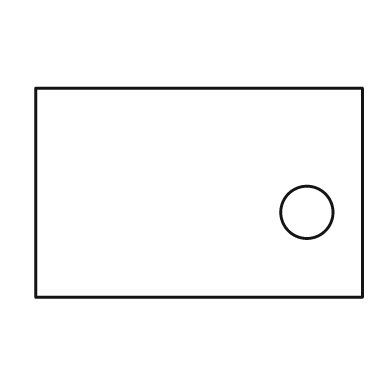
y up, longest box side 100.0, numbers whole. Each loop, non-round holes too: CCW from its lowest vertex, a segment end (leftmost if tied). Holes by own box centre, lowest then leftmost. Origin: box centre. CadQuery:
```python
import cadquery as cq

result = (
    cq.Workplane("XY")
    .moveTo(-50.0, -32.0)
    .lineTo(50.0, -32.0)
    .lineTo(50.0, 32.0)
    .lineTo(-50.0, 32.0)
    .close()
    .moveTo(33.0, -6.0)
    .circle(8.0)
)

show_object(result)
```